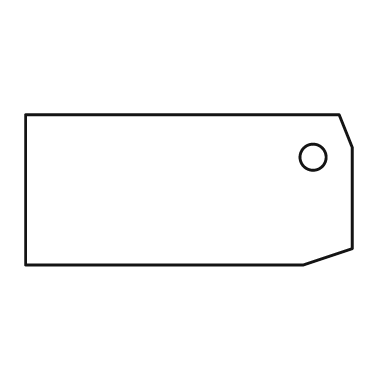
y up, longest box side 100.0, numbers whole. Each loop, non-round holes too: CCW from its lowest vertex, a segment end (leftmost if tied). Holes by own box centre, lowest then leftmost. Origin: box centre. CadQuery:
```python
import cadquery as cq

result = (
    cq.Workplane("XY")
    .moveTo(-50.0, -23.0)
    .lineTo(35.0, -23.0)
    .lineTo(50.0, -18.0)
    .lineTo(50.0, 13.0)
    .lineTo(46.0, 23.0)
    .lineTo(-50.0, 23.0)
    .close()
    .moveTo(38.0, 10.0)
    .circle(4.0)
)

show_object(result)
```